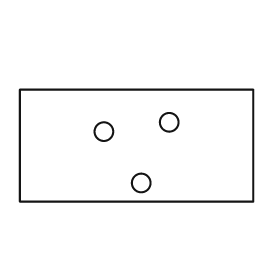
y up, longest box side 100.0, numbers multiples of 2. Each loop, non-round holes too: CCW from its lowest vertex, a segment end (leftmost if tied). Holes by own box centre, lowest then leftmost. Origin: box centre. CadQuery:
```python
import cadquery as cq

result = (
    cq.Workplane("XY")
    .moveTo(-50.0, -24.0)
    .lineTo(50.0, -24.0)
    .lineTo(50.0, 24.0)
    .lineTo(-50.0, 24.0)
    .close()
    .moveTo(2.0, -16.0)
    .circle(4.0)
    .moveTo(-14.0, 6.0)
    .circle(4.0)
    .moveTo(14.0, 10.0)
    .circle(4.0)
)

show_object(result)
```